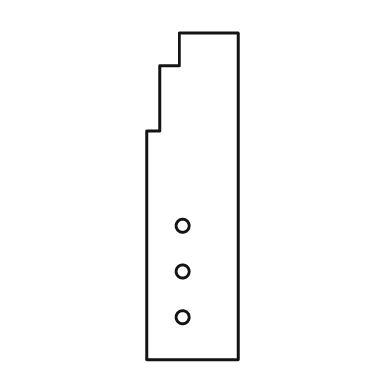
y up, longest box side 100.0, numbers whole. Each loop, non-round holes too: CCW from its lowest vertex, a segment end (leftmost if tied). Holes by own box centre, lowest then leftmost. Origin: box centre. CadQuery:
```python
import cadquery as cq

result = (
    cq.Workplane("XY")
    .moveTo(-14.0, -50.0)
    .lineTo(14.0, -50.0)
    .lineTo(14.0, 50.0)
    .lineTo(-4.0, 50.0)
    .lineTo(-4.0, 40.0)
    .lineTo(-10.0, 40.0)
    .lineTo(-10.0, 20.0)
    .lineTo(-14.0, 20.0)
    .close()
    .moveTo(-3.0, -37.0)
    .circle(2.0)
    .moveTo(-3.0, -23.0)
    .circle(2.0)
    .moveTo(-3.0, -9.0)
    .circle(2.0)
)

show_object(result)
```